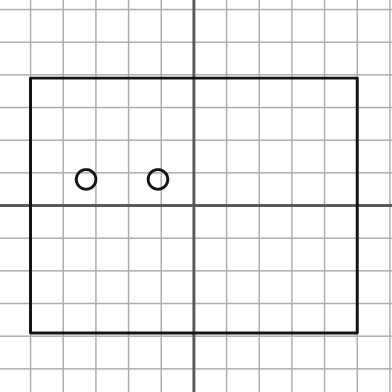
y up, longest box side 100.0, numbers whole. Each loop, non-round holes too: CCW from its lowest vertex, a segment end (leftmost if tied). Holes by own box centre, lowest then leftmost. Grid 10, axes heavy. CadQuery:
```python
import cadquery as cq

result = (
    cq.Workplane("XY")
    .moveTo(-50.0, -39.0)
    .lineTo(50.0, -39.0)
    .lineTo(50.0, 39.0)
    .lineTo(-50.0, 39.0)
    .close()
    .moveTo(-33.0, 8.0)
    .circle(3.0)
    .moveTo(-11.0, 8.0)
    .circle(3.0)
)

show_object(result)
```